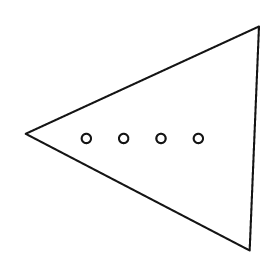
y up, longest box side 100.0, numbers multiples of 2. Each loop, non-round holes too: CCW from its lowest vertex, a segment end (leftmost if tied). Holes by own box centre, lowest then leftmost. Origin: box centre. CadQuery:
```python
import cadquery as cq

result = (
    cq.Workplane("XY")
    .moveTo(46.0, -48.0)
    .lineTo(50.0, 48.0)
    .lineTo(-50.0, 2.0)
    .close()
    .moveTo(-24.0, 0.0)
    .circle(2.0)
    .moveTo(-8.0, 0.0)
    .circle(2.0)
    .moveTo(8.0, 0.0)
    .circle(2.0)
    .moveTo(24.0, 0.0)
    .circle(2.0)
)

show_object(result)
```